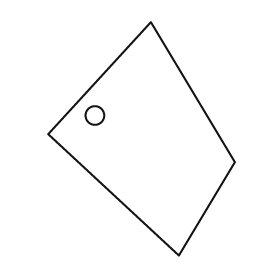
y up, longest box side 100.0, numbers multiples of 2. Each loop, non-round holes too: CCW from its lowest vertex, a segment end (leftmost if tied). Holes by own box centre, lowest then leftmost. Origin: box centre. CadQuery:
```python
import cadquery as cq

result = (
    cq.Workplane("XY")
    .moveTo(16.0, -50.0)
    .lineTo(40.0, -10.0)
    .lineTo(4.0, 50.0)
    .lineTo(-40.0, 2.0)
    .close()
    .moveTo(-20.0, 10.0)
    .circle(4.0)
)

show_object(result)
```